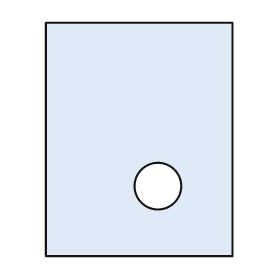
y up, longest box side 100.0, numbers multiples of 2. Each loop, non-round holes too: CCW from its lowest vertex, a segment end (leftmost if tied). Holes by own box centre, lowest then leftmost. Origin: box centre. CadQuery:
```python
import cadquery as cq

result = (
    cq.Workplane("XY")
    .moveTo(-40.0, -50.0)
    .lineTo(40.0, -50.0)
    .lineTo(40.0, 50.0)
    .lineTo(-40.0, 50.0)
    .close()
    .moveTo(8.0, -20.0)
    .circle(10.0)
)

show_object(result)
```